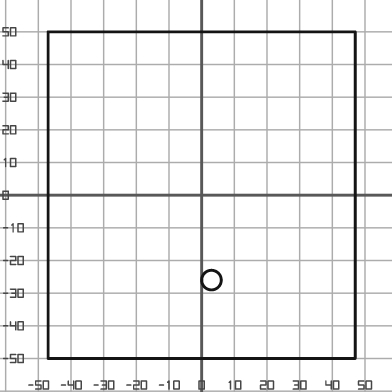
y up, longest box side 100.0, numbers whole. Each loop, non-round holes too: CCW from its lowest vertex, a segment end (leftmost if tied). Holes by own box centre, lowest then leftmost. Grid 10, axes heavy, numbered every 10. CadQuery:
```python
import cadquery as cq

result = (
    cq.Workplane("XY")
    .moveTo(-47.0, -50.0)
    .lineTo(47.0, -50.0)
    .lineTo(47.0, 50.0)
    .lineTo(-47.0, 50.0)
    .close()
    .moveTo(3.0, -26.0)
    .circle(3.0)
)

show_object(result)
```